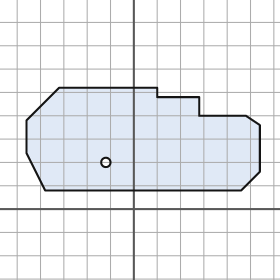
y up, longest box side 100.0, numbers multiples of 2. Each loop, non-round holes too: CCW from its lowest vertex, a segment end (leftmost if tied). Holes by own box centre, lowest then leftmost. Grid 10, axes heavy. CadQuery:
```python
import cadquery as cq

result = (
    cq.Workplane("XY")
    .moveTo(-38.0, 8.0)
    .lineTo(46.0, 8.0)
    .lineTo(54.0, 16.0)
    .lineTo(54.0, 36.0)
    .lineTo(48.0, 40.0)
    .lineTo(28.0, 40.0)
    .lineTo(28.0, 48.0)
    .lineTo(10.0, 48.0)
    .lineTo(10.0, 52.0)
    .lineTo(-32.0, 52.0)
    .lineTo(-46.0, 38.0)
    .lineTo(-46.0, 24.0)
    .close()
    .moveTo(-12.0, 20.0)
    .circle(2.0)
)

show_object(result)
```